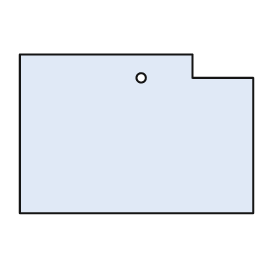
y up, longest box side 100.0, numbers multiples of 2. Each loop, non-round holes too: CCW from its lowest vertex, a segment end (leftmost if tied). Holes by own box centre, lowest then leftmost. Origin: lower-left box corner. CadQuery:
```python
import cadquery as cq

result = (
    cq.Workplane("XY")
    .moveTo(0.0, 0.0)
    .lineTo(100.0, 0.0)
    .lineTo(100.0, 58.0)
    .lineTo(74.0, 58.0)
    .lineTo(74.0, 68.0)
    .lineTo(0.0, 68.0)
    .close()
    .moveTo(52.0, 58.0)
    .circle(2.0)
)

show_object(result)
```